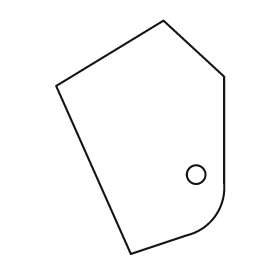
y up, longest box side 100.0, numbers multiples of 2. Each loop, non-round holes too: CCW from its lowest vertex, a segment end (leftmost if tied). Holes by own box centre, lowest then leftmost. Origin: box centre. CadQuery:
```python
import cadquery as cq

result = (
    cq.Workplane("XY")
    .moveTo(-4.0, -50.0)
    .lineTo(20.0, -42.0)
    .threePointArc((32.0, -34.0), (36.0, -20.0))
    .lineTo(36.0, 26.0)
    .lineTo(10.0, 50.0)
    .lineTo(-36.0, 22.0)
    .close()
    .moveTo(24.0, -16.0)
    .circle(4.0)
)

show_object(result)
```